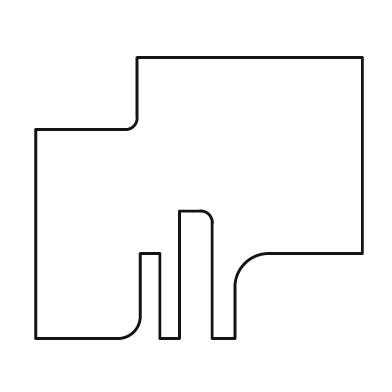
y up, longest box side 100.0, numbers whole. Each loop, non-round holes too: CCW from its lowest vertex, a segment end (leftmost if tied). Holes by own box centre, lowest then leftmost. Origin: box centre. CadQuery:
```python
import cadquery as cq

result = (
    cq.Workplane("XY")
    .moveTo(-50.0, -43.0)
    .lineTo(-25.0, -43.0)
    .threePointArc((-20.0, -41.0), (-18.0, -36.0))
    .lineTo(-18.0, -17.0)
    .lineTo(-12.0, -17.0)
    .lineTo(-12.0, -43.0)
    .lineTo(-6.0, -43.0)
    .lineTo(-6.0, -4.0)
    .lineTo(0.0, -4.0)
    .threePointArc((3.0, -5.0), (4.0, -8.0))
    .lineTo(4.0, -43.0)
    .lineTo(11.0, -43.0)
    .lineTo(11.0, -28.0)
    .threePointArc((14.0, -20.0), (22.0, -17.0))
    .lineTo(50.0, -17.0)
    .lineTo(50.0, 43.0)
    .lineTo(-19.0, 43.0)
    .lineTo(-19.0, 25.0)
    .threePointArc((-20.0, 22.0), (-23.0, 21.0))
    .lineTo(-50.0, 21.0)
    .close()
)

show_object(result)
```